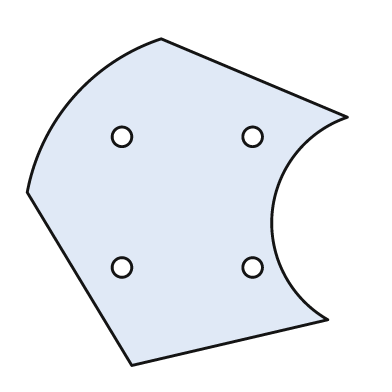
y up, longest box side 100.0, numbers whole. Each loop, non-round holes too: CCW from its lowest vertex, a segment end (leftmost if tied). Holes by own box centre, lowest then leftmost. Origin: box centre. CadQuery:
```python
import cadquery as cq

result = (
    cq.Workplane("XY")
    .moveTo(-17.0, -50.0)
    .lineTo(43.0, -36.0)
    .threePointArc((26.0, -3.0), (49.0, 26.0))
    .lineTo(-8.0, 50.0)
    .threePointArc((-35.0, 32.0), (-49.0, 3.0))
    .close()
    .moveTo(-20.0, -20.0)
    .circle(3.0)
    .moveTo(20.0, -20.0)
    .circle(3.0)
    .moveTo(-20.0, 20.0)
    .circle(3.0)
    .moveTo(20.0, 20.0)
    .circle(3.0)
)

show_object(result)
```